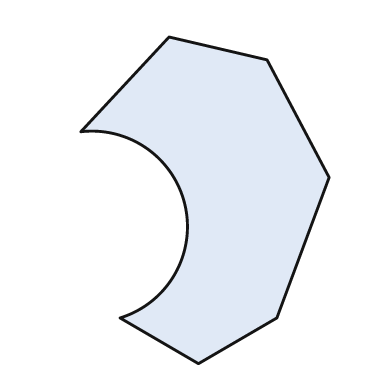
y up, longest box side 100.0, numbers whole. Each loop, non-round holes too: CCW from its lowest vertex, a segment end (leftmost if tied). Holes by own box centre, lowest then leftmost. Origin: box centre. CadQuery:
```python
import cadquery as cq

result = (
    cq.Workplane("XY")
    .moveTo(-2.0, -50.0)
    .lineTo(22.0, -36.0)
    .lineTo(38.0, 7.0)
    .lineTo(19.0, 43.0)
    .lineTo(-11.0, 50.0)
    .lineTo(-38.0, 21.0)
    .threePointArc((-6.0, -2.0), (-26.0, -36.0))
    .close()
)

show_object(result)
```